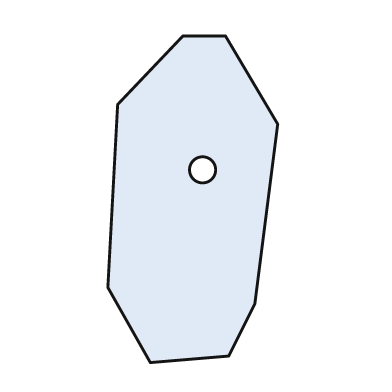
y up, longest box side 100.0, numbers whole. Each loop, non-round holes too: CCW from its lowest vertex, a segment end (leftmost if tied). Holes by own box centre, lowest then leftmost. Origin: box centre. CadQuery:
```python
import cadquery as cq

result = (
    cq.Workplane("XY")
    .moveTo(-13.0, -50.0)
    .lineTo(11.0, -48.0)
    .lineTo(19.0, -32.0)
    .lineTo(26.0, 23.0)
    .lineTo(10.0, 50.0)
    .lineTo(-3.0, 50.0)
    .lineTo(-23.0, 29.0)
    .lineTo(-26.0, -27.0)
    .close()
    .moveTo(3.0, 9.0)
    .circle(4.0)
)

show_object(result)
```